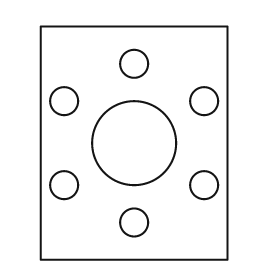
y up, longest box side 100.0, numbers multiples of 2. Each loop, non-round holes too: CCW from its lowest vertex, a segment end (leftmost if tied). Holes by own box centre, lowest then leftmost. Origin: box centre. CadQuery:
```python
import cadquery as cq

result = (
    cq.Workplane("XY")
    .moveTo(-40.0, -50.0)
    .lineTo(40.0, -50.0)
    .lineTo(40.0, 50.0)
    .lineTo(-40.0, 50.0)
    .close()
    .moveTo(0.0, -34.0)
    .circle(6.0)
    .moveTo(-30.0, -18.0)
    .circle(6.0)
    .moveTo(30.0, -18.0)
    .circle(6.0)
    .moveTo(0.0, 0.0)
    .circle(18.0)
    .moveTo(-30.0, 18.0)
    .circle(6.0)
    .moveTo(30.0, 18.0)
    .circle(6.0)
    .moveTo(0.0, 34.0)
    .circle(6.0)
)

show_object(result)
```